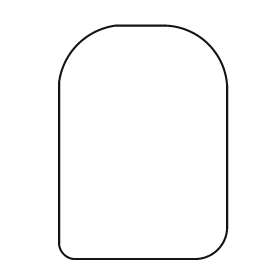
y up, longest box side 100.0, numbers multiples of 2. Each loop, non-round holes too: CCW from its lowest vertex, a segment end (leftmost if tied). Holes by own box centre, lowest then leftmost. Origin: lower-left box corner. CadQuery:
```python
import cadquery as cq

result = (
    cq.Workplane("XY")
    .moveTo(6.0, 0.0)
    .lineTo(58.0, 0.0)
    .threePointArc((68.0, 4.0), (72.0, 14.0))
    .lineTo(72.0, 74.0)
    .threePointArc((64.0, 92.0), (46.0, 100.0))
    .lineTo(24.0, 100.0)
    .threePointArc((8.0, 92.0), (0.0, 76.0))
    .lineTo(0.0, 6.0)
    .threePointArc((2.0, 2.0), (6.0, 0.0))
    .close()
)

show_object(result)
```